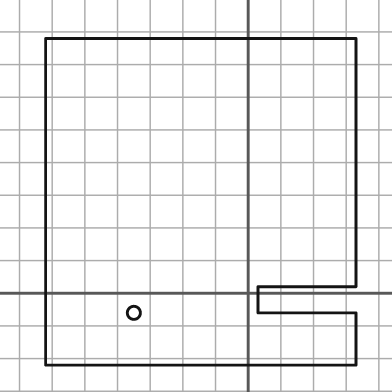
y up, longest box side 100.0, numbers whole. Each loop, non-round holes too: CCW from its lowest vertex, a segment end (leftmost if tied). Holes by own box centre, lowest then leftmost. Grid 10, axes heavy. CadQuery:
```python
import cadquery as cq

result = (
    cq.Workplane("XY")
    .moveTo(-62.0, -22.0)
    .lineTo(33.0, -22.0)
    .lineTo(33.0, -6.0)
    .lineTo(3.0, -6.0)
    .lineTo(3.0, 2.0)
    .lineTo(33.0, 2.0)
    .lineTo(33.0, 78.0)
    .lineTo(-62.0, 78.0)
    .close()
    .moveTo(-35.0, -6.0)
    .circle(2.0)
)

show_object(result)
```